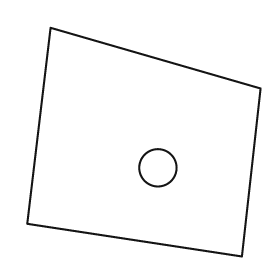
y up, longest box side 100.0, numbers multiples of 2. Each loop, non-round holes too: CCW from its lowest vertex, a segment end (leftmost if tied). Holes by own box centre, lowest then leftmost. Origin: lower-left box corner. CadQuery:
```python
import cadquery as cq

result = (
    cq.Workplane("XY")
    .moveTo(92.0, 0.0)
    .lineTo(100.0, 72.0)
    .lineTo(10.0, 98.0)
    .lineTo(0.0, 14.0)
    .close()
    .moveTo(56.0, 38.0)
    .circle(8.0)
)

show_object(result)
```